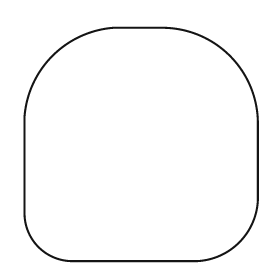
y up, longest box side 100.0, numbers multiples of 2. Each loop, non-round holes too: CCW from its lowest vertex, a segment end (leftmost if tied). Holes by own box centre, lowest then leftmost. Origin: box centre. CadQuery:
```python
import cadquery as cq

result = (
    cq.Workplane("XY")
    .moveTo(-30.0, -50.0)
    .lineTo(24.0, -50.0)
    .threePointArc((42.0, -42.0), (50.0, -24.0))
    .lineTo(50.0, 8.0)
    .threePointArc((38.0, 38.0), (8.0, 50.0))
    .lineTo(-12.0, 50.0)
    .threePointArc((-38.0, 38.0), (-50.0, 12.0))
    .lineTo(-50.0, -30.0)
    .threePointArc((-44.0, -44.0), (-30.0, -50.0))
    .close()
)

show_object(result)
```